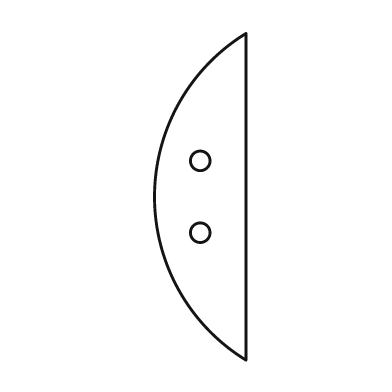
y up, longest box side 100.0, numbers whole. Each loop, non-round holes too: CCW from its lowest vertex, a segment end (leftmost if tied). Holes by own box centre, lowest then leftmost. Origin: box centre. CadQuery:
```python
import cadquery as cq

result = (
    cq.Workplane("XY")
    .moveTo(14.0, -50.0)
    .lineTo(14.0, 50.0)
    .threePointArc((-14.0, 0.0), (14.0, -50.0))
    .close()
    .moveTo(0.0, -11.0)
    .circle(3.0)
    .moveTo(0.0, 11.0)
    .circle(3.0)
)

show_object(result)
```